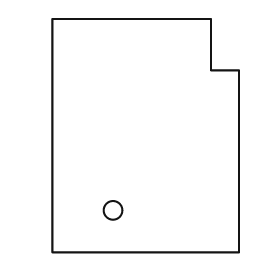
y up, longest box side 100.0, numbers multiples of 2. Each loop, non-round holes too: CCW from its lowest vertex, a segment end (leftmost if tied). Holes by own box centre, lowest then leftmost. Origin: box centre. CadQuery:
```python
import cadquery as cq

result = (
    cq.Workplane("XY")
    .moveTo(-40.0, -50.0)
    .lineTo(40.0, -50.0)
    .lineTo(40.0, 28.0)
    .lineTo(28.0, 28.0)
    .lineTo(28.0, 50.0)
    .lineTo(-40.0, 50.0)
    .close()
    .moveTo(-14.0, -32.0)
    .circle(4.0)
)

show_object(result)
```